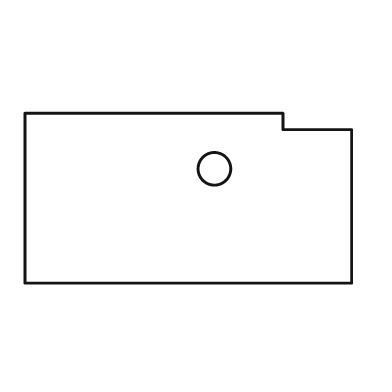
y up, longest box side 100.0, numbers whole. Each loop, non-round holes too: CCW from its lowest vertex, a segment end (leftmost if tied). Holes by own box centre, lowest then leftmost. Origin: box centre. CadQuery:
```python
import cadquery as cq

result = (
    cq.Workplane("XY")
    .moveTo(-50.0, -26.0)
    .lineTo(50.0, -26.0)
    .lineTo(50.0, 21.0)
    .lineTo(29.0, 21.0)
    .lineTo(29.0, 26.0)
    .lineTo(-50.0, 26.0)
    .close()
    .moveTo(8.0, 9.0)
    .circle(5.0)
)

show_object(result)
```